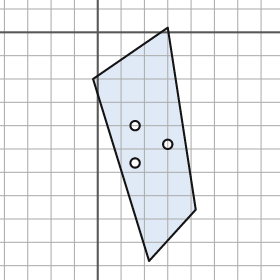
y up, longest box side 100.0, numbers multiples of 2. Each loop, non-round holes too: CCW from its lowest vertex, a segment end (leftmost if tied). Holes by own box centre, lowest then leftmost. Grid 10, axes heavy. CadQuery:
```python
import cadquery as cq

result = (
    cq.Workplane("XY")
    .moveTo(22.0, -98.0)
    .lineTo(42.0, -76.0)
    .lineTo(30.0, 2.0)
    .lineTo(-2.0, -20.0)
    .close()
    .moveTo(16.0, -56.0)
    .circle(2.0)
    .moveTo(30.0, -48.0)
    .circle(2.0)
    .moveTo(16.0, -40.0)
    .circle(2.0)
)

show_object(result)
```